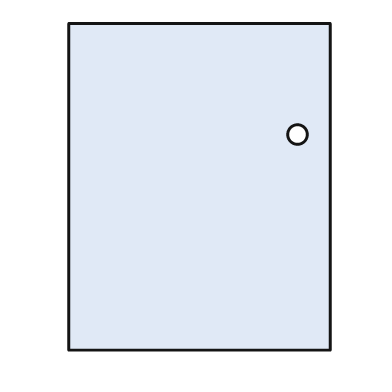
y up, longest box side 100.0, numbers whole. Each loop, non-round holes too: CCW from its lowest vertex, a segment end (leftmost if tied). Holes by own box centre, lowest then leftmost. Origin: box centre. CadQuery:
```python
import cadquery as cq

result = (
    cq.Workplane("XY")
    .moveTo(-40.0, -50.0)
    .lineTo(40.0, -50.0)
    .lineTo(40.0, 50.0)
    .lineTo(-40.0, 50.0)
    .close()
    .moveTo(30.0, 16.0)
    .circle(3.0)
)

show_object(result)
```